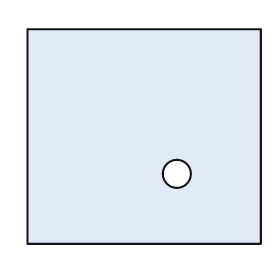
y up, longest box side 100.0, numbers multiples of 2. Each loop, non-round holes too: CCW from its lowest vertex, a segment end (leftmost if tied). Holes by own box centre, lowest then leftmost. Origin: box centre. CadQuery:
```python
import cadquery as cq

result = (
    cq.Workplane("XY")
    .moveTo(-50.0, -46.0)
    .lineTo(50.0, -46.0)
    .lineTo(50.0, 46.0)
    .lineTo(-50.0, 46.0)
    .close()
    .moveTo(14.0, -16.0)
    .circle(6.0)
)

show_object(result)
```